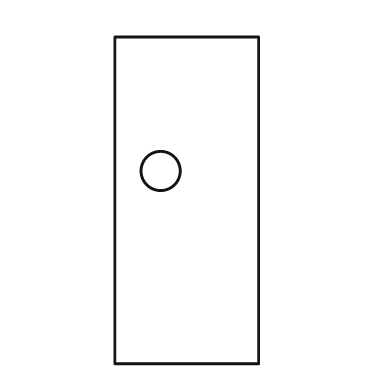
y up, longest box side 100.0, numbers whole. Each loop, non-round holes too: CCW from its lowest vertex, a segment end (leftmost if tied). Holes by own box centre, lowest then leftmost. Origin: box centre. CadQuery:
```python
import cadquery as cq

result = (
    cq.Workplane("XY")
    .moveTo(-22.0, -50.0)
    .lineTo(22.0, -50.0)
    .lineTo(22.0, 50.0)
    .lineTo(-22.0, 50.0)
    .close()
    .moveTo(-8.0, 9.0)
    .circle(6.0)
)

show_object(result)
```